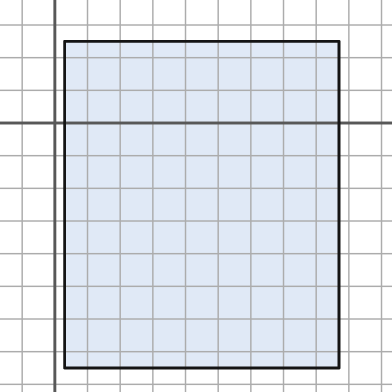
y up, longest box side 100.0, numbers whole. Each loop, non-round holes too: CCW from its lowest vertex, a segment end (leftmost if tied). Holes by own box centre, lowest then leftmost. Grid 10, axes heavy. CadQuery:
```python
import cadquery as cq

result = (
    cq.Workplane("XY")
    .moveTo(3.0, -75.0)
    .lineTo(87.0, -75.0)
    .lineTo(87.0, 25.0)
    .lineTo(3.0, 25.0)
    .close()
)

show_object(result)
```